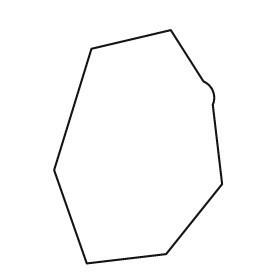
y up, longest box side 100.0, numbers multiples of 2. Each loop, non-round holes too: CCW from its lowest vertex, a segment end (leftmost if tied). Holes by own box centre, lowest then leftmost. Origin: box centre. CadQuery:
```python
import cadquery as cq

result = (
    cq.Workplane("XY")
    .moveTo(-22.0, -50.0)
    .lineTo(12.0, -46.0)
    .lineTo(36.0, -16.0)
    .lineTo(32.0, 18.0)
    .threePointArc((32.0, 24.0), (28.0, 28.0))
    .lineTo(14.0, 50.0)
    .lineTo(-20.0, 42.0)
    .lineTo(-36.0, -10.0)
    .close()
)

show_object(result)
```